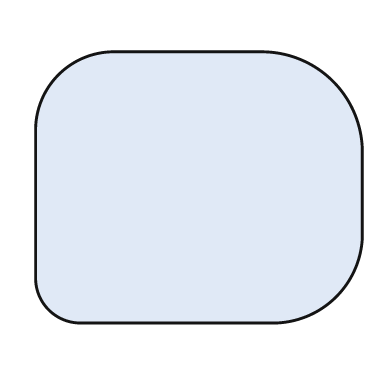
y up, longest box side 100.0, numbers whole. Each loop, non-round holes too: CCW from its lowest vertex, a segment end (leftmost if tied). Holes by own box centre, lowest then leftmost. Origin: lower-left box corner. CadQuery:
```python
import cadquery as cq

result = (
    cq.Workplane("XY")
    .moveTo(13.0, 0.0)
    .lineTo(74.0, 0.0)
    .threePointArc((92.0, 8.0), (100.0, 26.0))
    .lineTo(100.0, 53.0)
    .threePointArc((91.0, 74.0), (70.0, 83.0))
    .lineTo(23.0, 83.0)
    .threePointArc((7.0, 76.0), (0.0, 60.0))
    .lineTo(0.0, 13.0)
    .threePointArc((4.0, 4.0), (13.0, 0.0))
    .close()
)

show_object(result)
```